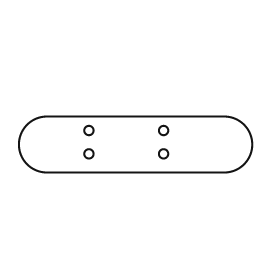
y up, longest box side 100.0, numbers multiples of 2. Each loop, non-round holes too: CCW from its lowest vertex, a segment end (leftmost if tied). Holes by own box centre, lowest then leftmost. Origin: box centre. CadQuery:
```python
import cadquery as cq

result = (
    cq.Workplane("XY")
    .moveTo(-38.0, -12.0)
    .lineTo(38.0, -12.0)
    .threePointArc((50.0, 0.0), (38.0, 12.0))
    .lineTo(-38.0, 12.0)
    .threePointArc((-50.0, 0.0), (-38.0, -12.0))
    .close()
    .moveTo(-20.0, -4.0)
    .circle(2.0)
    .moveTo(12.0, -4.0)
    .circle(2.0)
    .moveTo(-20.0, 6.0)
    .circle(2.0)
    .moveTo(12.0, 6.0)
    .circle(2.0)
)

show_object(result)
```